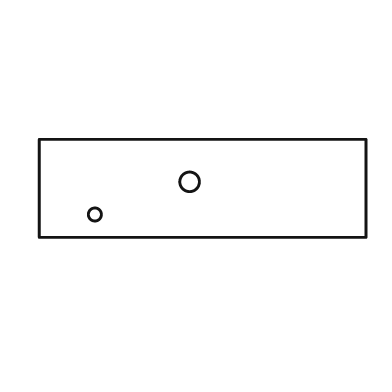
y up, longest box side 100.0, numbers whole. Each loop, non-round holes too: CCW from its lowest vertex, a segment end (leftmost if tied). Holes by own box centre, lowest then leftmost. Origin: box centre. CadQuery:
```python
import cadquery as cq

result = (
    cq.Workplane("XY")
    .moveTo(-50.0, -15.0)
    .lineTo(50.0, -15.0)
    .lineTo(50.0, 15.0)
    .lineTo(-50.0, 15.0)
    .close()
    .moveTo(-33.0, -8.0)
    .circle(2.0)
    .moveTo(-4.0, 2.0)
    .circle(3.0)
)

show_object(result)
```